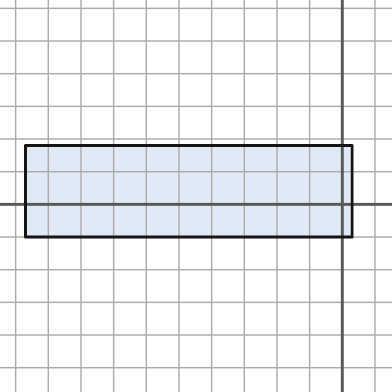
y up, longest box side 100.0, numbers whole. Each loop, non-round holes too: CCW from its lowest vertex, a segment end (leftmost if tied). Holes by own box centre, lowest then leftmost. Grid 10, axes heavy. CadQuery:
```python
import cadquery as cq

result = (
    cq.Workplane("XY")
    .moveTo(-97.0, -10.0)
    .lineTo(3.0, -10.0)
    .lineTo(3.0, 18.0)
    .lineTo(-97.0, 18.0)
    .close()
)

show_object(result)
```